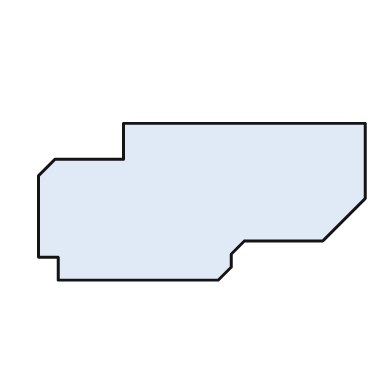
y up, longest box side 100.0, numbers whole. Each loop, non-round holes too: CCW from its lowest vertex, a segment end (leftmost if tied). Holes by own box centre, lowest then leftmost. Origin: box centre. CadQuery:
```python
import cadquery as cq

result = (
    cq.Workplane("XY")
    .moveTo(-44.0, -24.0)
    .lineTo(5.0, -24.0)
    .lineTo(9.0, -20.0)
    .lineTo(9.0, -16.0)
    .lineTo(13.0, -12.0)
    .lineTo(37.0, -12.0)
    .lineTo(50.0, 1.0)
    .lineTo(50.0, 24.0)
    .lineTo(-24.0, 24.0)
    .lineTo(-24.0, 13.0)
    .lineTo(-45.0, 13.0)
    .lineTo(-50.0, 8.0)
    .lineTo(-50.0, -17.0)
    .lineTo(-44.0, -17.0)
    .close()
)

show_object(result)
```